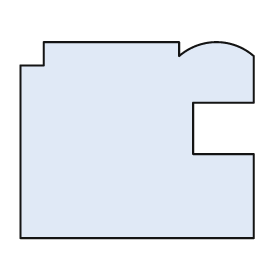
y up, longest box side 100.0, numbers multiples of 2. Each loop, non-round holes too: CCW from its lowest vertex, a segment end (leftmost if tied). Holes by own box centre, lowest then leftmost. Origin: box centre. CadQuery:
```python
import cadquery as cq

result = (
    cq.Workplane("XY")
    .moveTo(-50.0, -42.0)
    .lineTo(50.0, -42.0)
    .lineTo(50.0, -6.0)
    .lineTo(24.0, -6.0)
    .lineTo(24.0, 16.0)
    .lineTo(50.0, 16.0)
    .lineTo(50.0, 36.0)
    .threePointArc((34.0, 42.0), (18.0, 36.0))
    .lineTo(18.0, 42.0)
    .lineTo(-40.0, 42.0)
    .lineTo(-40.0, 32.0)
    .lineTo(-50.0, 32.0)
    .close()
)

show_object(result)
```